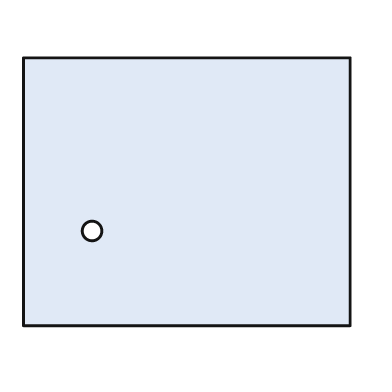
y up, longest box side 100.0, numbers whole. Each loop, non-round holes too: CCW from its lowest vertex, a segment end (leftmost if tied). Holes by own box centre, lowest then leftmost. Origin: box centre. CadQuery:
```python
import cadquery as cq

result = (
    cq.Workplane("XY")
    .moveTo(-50.0, -41.0)
    .lineTo(50.0, -41.0)
    .lineTo(50.0, 41.0)
    .lineTo(-50.0, 41.0)
    .close()
    .moveTo(-29.0, -12.0)
    .circle(3.0)
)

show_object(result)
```